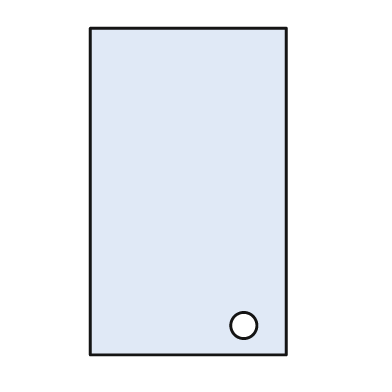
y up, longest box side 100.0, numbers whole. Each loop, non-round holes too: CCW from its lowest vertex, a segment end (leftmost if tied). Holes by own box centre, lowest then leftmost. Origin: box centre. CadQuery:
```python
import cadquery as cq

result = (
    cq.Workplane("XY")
    .moveTo(-30.0, -50.0)
    .lineTo(30.0, -50.0)
    .lineTo(30.0, 50.0)
    .lineTo(-30.0, 50.0)
    .close()
    .moveTo(17.0, -41.0)
    .circle(4.0)
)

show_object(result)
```